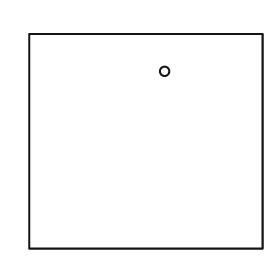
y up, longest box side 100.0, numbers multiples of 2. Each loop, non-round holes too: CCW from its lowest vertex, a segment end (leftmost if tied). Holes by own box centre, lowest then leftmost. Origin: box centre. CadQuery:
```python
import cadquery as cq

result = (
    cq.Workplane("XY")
    .moveTo(-50.0, -46.0)
    .lineTo(50.0, -46.0)
    .lineTo(50.0, 46.0)
    .lineTo(-50.0, 46.0)
    .close()
    .moveTo(8.0, 30.0)
    .circle(2.0)
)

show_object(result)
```